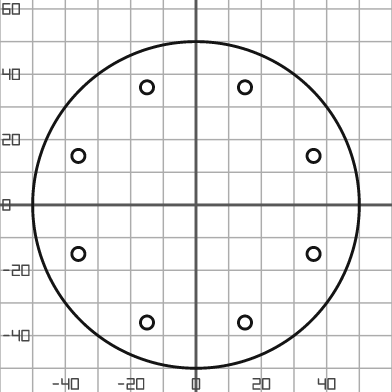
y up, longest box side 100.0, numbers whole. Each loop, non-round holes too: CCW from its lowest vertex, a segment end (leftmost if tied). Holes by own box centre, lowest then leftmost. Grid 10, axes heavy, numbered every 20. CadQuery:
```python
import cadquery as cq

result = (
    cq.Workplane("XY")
    .moveTo(0.0, 0.0)
    .circle(50.0)
    .moveTo(-15.0, -36.0)
    .circle(2.0)
    .moveTo(15.0, -36.0)
    .circle(2.0)
    .moveTo(-36.0, -15.0)
    .circle(2.0)
    .moveTo(36.0, -15.0)
    .circle(2.0)
    .moveTo(-36.0, 15.0)
    .circle(2.0)
    .moveTo(36.0, 15.0)
    .circle(2.0)
    .moveTo(-15.0, 36.0)
    .circle(2.0)
    .moveTo(15.0, 36.0)
    .circle(2.0)
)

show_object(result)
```